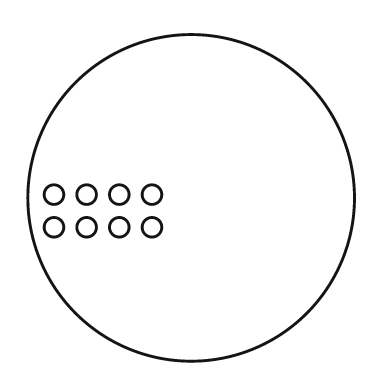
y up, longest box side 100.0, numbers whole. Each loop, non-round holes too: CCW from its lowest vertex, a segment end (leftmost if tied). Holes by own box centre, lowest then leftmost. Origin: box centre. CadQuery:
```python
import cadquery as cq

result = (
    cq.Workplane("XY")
    .moveTo(0.0, 0.0)
    .circle(50.0)
    .moveTo(-42.0, -9.0)
    .circle(3.0)
    .moveTo(-32.0, -9.0)
    .circle(3.0)
    .moveTo(-22.0, -9.0)
    .circle(3.0)
    .moveTo(-12.0, -9.0)
    .circle(3.0)
    .moveTo(-42.0, 1.0)
    .circle(3.0)
    .moveTo(-32.0, 1.0)
    .circle(3.0)
    .moveTo(-22.0, 1.0)
    .circle(3.0)
    .moveTo(-12.0, 1.0)
    .circle(3.0)
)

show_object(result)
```